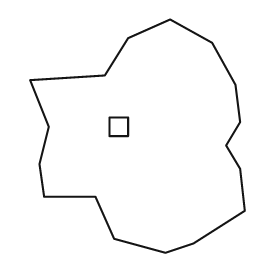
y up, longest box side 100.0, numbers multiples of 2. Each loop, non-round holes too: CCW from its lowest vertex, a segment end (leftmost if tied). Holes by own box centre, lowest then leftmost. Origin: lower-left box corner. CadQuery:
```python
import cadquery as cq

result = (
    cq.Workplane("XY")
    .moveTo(58.0, 0.0)
    .lineTo(70.0, 4.0)
    .lineTo(92.0, 18.0)
    .lineTo(90.0, 36.0)
    .lineTo(84.0, 46.0)
    .lineTo(90.0, 56.0)
    .lineTo(88.0, 72.0)
    .lineTo(78.0, 90.0)
    .lineTo(60.0, 100.0)
    .lineTo(42.0, 92.0)
    .lineTo(32.0, 76.0)
    .lineTo(0.0, 74.0)
    .lineTo(8.0, 54.0)
    .lineTo(4.0, 38.0)
    .lineTo(6.0, 24.0)
    .lineTo(28.0, 24.0)
    .lineTo(36.0, 6.0)
    .close()
    .moveTo(34.0, 50.0)
    .lineTo(42.0, 50.0)
    .lineTo(42.0, 58.0)
    .lineTo(34.0, 58.0)
    .close()
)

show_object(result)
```